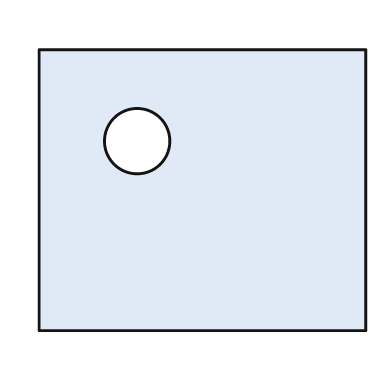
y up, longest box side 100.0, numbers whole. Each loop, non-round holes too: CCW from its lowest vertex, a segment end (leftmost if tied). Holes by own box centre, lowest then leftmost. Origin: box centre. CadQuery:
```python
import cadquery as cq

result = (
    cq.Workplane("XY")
    .moveTo(-50.0, -43.0)
    .lineTo(50.0, -43.0)
    .lineTo(50.0, 43.0)
    .lineTo(-50.0, 43.0)
    .close()
    .moveTo(-20.0, 15.0)
    .circle(10.0)
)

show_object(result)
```